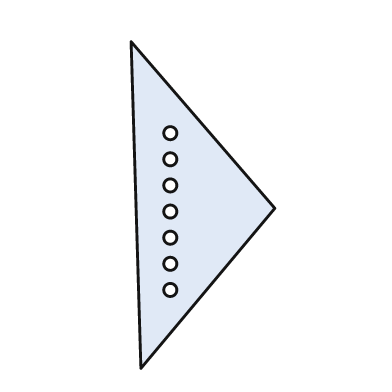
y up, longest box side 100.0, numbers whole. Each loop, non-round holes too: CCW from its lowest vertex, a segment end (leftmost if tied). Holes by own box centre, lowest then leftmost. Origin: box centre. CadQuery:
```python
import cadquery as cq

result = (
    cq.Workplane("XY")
    .moveTo(-19.0, -50.0)
    .lineTo(22.0, -1.0)
    .lineTo(-22.0, 50.0)
    .close()
    .moveTo(-10.0, -26.0)
    .circle(2.0)
    .moveTo(-10.0, -18.0)
    .circle(2.0)
    .moveTo(-10.0, -10.0)
    .circle(2.0)
    .moveTo(-10.0, -2.0)
    .circle(2.0)
    .moveTo(-10.0, 6.0)
    .circle(2.0)
    .moveTo(-10.0, 14.0)
    .circle(2.0)
    .moveTo(-10.0, 22.0)
    .circle(2.0)
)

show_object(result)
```